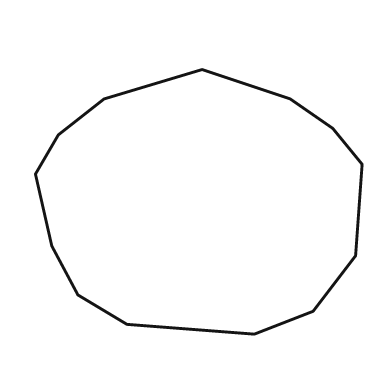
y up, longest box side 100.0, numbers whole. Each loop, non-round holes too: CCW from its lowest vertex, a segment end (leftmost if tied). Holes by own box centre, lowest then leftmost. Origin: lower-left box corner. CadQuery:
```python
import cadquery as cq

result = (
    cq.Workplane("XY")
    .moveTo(67.0, 0.0)
    .lineTo(85.0, 7.0)
    .lineTo(98.0, 24.0)
    .lineTo(100.0, 52.0)
    .lineTo(91.0, 63.0)
    .lineTo(78.0, 72.0)
    .lineTo(51.0, 81.0)
    .lineTo(21.0, 72.0)
    .lineTo(7.0, 61.0)
    .lineTo(0.0, 49.0)
    .lineTo(5.0, 27.0)
    .lineTo(13.0, 12.0)
    .lineTo(28.0, 3.0)
    .close()
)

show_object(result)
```